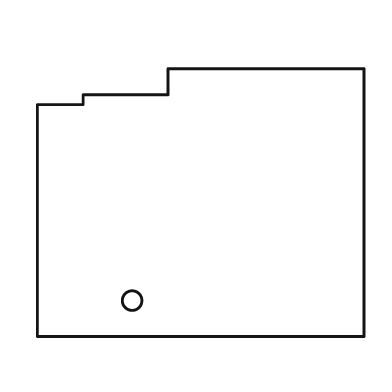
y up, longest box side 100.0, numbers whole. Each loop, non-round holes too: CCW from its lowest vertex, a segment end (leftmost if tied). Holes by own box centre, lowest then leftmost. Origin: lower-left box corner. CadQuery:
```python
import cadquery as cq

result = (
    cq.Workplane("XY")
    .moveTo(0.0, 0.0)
    .lineTo(100.0, 0.0)
    .lineTo(100.0, 82.0)
    .lineTo(40.0, 82.0)
    .lineTo(40.0, 74.0)
    .lineTo(14.0, 74.0)
    .lineTo(14.0, 71.0)
    .lineTo(0.0, 71.0)
    .close()
    .moveTo(29.0, 11.0)
    .circle(3.0)
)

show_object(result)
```